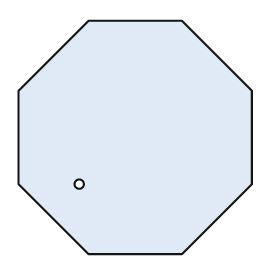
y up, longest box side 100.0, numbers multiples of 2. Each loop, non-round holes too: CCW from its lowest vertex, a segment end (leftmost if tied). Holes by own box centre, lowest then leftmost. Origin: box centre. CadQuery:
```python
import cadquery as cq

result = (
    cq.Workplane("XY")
    .moveTo(-20.0, -50.0)
    .lineTo(20.0, -50.0)
    .lineTo(50.0, -20.0)
    .lineTo(50.0, 20.0)
    .lineTo(20.0, 50.0)
    .lineTo(-20.0, 50.0)
    .lineTo(-50.0, 20.0)
    .lineTo(-50.0, -20.0)
    .close()
    .moveTo(-24.0, -20.0)
    .circle(2.0)
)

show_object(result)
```